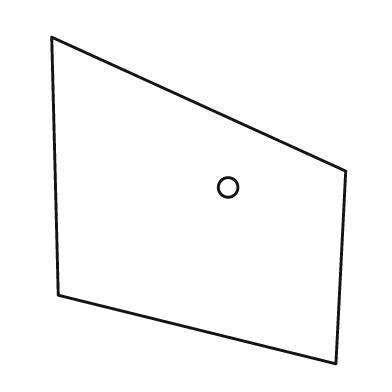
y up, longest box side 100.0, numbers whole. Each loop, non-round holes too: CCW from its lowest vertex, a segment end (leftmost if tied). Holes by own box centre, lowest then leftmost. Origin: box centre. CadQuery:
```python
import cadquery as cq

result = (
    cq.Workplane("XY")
    .moveTo(42.0, -50.0)
    .lineTo(45.0, 9.0)
    .lineTo(-45.0, 50.0)
    .lineTo(-43.0, -29.0)
    .close()
    .moveTo(9.0, 4.0)
    .circle(3.0)
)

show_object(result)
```